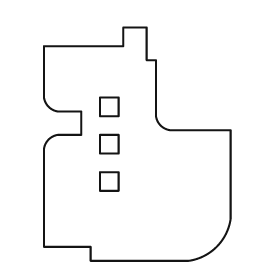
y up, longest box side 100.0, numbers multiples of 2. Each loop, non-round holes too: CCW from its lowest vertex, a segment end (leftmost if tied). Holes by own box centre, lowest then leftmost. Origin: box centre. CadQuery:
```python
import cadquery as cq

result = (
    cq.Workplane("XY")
    .moveTo(-20.0, -50.0)
    .lineTo(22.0, -50.0)
    .threePointArc((34.0, -44.0), (40.0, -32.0))
    .lineTo(40.0, 6.0)
    .lineTo(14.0, 6.0)
    .threePointArc((10.0, 8.0), (8.0, 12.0))
    .lineTo(8.0, 36.0)
    .lineTo(4.0, 36.0)
    .lineTo(4.0, 50.0)
    .lineTo(-6.0, 50.0)
    .lineTo(-6.0, 42.0)
    .lineTo(-40.0, 42.0)
    .lineTo(-40.0, 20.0)
    .threePointArc((-38.0, 16.0), (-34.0, 14.0))
    .lineTo(-24.0, 14.0)
    .lineTo(-24.0, 4.0)
    .lineTo(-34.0, 4.0)
    .threePointArc((-38.0, 2.0), (-40.0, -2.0))
    .lineTo(-40.0, -44.0)
    .lineTo(-20.0, -44.0)
    .close()
    .moveTo(-16.0, -20.0)
    .lineTo(-8.0, -20.0)
    .lineTo(-8.0, -12.0)
    .lineTo(-16.0, -12.0)
    .close()
    .moveTo(-16.0, -4.0)
    .lineTo(-8.0, -4.0)
    .lineTo(-8.0, 4.0)
    .lineTo(-16.0, 4.0)
    .close()
    .moveTo(-16.0, 12.0)
    .lineTo(-8.0, 12.0)
    .lineTo(-8.0, 20.0)
    .lineTo(-16.0, 20.0)
    .close()
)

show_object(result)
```